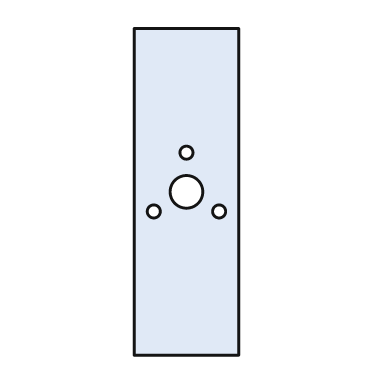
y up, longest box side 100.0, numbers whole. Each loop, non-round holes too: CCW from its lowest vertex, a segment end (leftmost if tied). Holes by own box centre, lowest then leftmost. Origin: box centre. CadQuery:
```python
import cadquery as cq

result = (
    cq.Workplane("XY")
    .moveTo(-16.0, -50.0)
    .lineTo(16.0, -50.0)
    .lineTo(16.0, 50.0)
    .lineTo(-16.0, 50.0)
    .close()
    .moveTo(-10.0, -6.0)
    .circle(2.0)
    .moveTo(10.0, -6.0)
    .circle(2.0)
    .moveTo(0.0, 0.0)
    .circle(5.0)
    .moveTo(0.0, 12.0)
    .circle(2.0)
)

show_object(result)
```